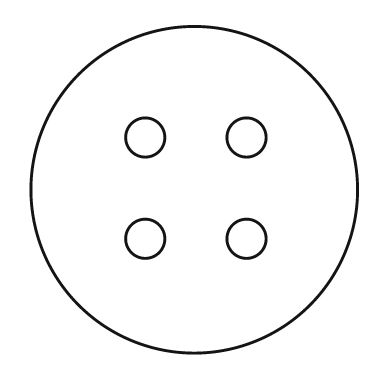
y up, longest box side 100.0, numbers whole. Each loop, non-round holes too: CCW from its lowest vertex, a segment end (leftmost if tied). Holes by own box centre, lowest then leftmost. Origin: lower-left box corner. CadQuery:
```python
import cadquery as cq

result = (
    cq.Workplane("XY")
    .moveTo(50.0, 50.0)
    .circle(50.0)
    .moveTo(35.0, 35.0)
    .circle(6.0)
    .moveTo(66.0, 35.0)
    .circle(6.0)
    .moveTo(35.0, 66.0)
    .circle(6.0)
    .moveTo(66.0, 66.0)
    .circle(6.0)
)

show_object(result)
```